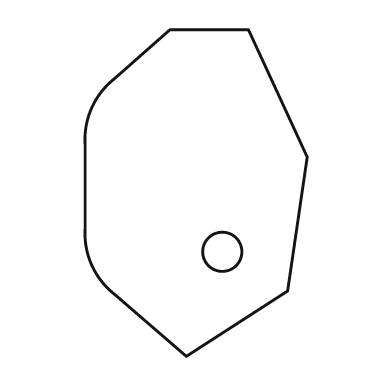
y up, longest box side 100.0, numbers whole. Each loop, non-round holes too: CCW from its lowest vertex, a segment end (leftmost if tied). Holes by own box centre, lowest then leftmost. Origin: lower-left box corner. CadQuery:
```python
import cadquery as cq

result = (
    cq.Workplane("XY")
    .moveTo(31.0, 0.0)
    .lineTo(62.0, 20.0)
    .lineTo(68.0, 61.0)
    .lineTo(50.0, 100.0)
    .lineTo(26.0, 100.0)
    .lineTo(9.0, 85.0)
    .threePointArc((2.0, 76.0), (0.0, 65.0))
    .lineTo(0.0, 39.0)
    .threePointArc((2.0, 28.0), (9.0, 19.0))
    .close()
    .moveTo(42.0, 32.0)
    .circle(6.0)
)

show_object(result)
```